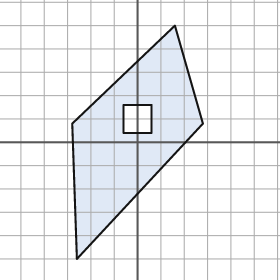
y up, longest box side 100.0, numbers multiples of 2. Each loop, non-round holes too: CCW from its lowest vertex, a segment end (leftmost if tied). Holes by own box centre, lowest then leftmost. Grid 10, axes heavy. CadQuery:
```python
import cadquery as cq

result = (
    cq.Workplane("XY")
    .moveTo(-26.0, -50.0)
    .lineTo(28.0, 8.0)
    .lineTo(16.0, 50.0)
    .lineTo(-28.0, 8.0)
    .close()
    .moveTo(-6.0, 4.0)
    .lineTo(6.0, 4.0)
    .lineTo(6.0, 16.0)
    .lineTo(-6.0, 16.0)
    .close()
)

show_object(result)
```